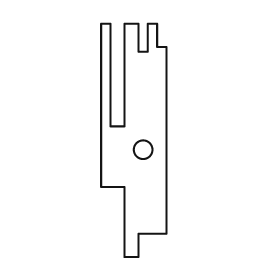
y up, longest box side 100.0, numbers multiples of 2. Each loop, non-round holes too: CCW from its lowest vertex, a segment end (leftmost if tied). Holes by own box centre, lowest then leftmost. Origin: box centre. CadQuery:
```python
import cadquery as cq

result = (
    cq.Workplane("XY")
    .moveTo(-4.0, -50.0)
    .lineTo(2.0, -50.0)
    .lineTo(2.0, -40.0)
    .lineTo(14.0, -40.0)
    .lineTo(14.0, 40.0)
    .lineTo(10.0, 40.0)
    .lineTo(10.0, 50.0)
    .lineTo(6.0, 50.0)
    .lineTo(6.0, 38.0)
    .lineTo(2.0, 38.0)
    .lineTo(2.0, 50.0)
    .lineTo(-4.0, 50.0)
    .lineTo(-4.0, 6.0)
    .lineTo(-10.0, 6.0)
    .lineTo(-10.0, 50.0)
    .lineTo(-14.0, 50.0)
    .lineTo(-14.0, -20.0)
    .lineTo(-4.0, -20.0)
    .close()
    .moveTo(4.0, -4.0)
    .circle(4.0)
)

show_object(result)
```